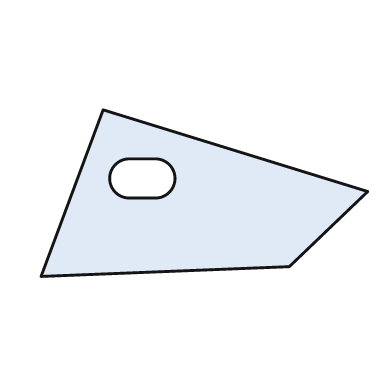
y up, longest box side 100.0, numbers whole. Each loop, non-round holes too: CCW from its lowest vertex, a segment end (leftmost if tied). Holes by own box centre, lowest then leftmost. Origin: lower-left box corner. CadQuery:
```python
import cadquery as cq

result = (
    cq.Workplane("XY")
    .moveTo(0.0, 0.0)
    .lineTo(76.0, 3.0)
    .lineTo(100.0, 26.0)
    .lineTo(19.0, 51.0)
    .close()
    .moveTo(27.0, 24.0)
    .lineTo(35.0, 24.0)
    .threePointArc((41.0, 30.0), (35.0, 36.0))
    .lineTo(27.0, 36.0)
    .threePointArc((21.0, 30.0), (27.0, 24.0))
    .close()
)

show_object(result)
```